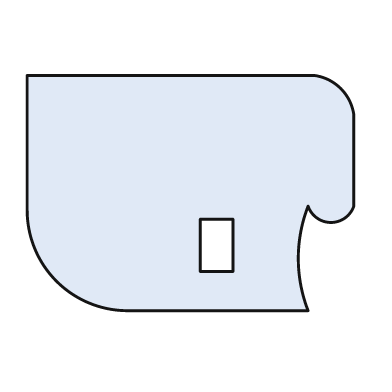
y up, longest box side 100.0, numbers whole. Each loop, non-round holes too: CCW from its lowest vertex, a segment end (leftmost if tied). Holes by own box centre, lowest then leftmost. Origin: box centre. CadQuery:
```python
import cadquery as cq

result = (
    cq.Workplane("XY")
    .moveTo(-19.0, -36.0)
    .lineTo(36.0, -36.0)
    .threePointArc((33.0, -20.0), (36.0, -4.0))
    .threePointArc((43.0, -9.0), (50.0, -4.0))
    .lineTo(50.0, 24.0)
    .threePointArc((46.0, 32.0), (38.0, 36.0))
    .lineTo(-50.0, 36.0)
    .lineTo(-50.0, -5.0)
    .threePointArc((-41.0, -27.0), (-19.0, -36.0))
    .close()
    .moveTo(3.0, -24.0)
    .lineTo(13.0, -24.0)
    .lineTo(13.0, -8.0)
    .lineTo(3.0, -8.0)
    .close()
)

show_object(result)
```